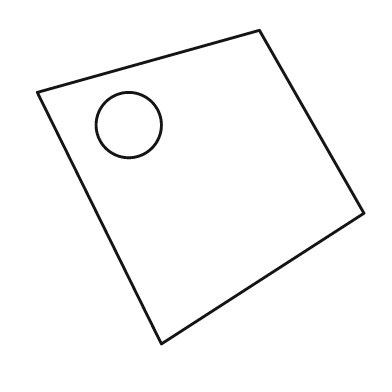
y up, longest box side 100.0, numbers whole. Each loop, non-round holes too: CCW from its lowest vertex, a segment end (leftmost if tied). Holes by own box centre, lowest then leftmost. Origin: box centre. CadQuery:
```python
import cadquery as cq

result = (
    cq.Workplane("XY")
    .moveTo(-12.0, -48.0)
    .lineTo(50.0, -8.0)
    .lineTo(18.0, 48.0)
    .lineTo(-50.0, 29.0)
    .close()
    .moveTo(-22.0, 19.0)
    .circle(10.0)
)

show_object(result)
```